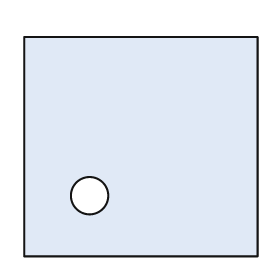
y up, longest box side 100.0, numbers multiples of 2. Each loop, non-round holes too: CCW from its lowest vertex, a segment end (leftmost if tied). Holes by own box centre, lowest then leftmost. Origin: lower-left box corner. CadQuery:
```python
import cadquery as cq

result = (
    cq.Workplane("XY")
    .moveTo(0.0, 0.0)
    .lineTo(100.0, 0.0)
    .lineTo(100.0, 94.0)
    .lineTo(0.0, 94.0)
    .close()
    .moveTo(28.0, 26.0)
    .circle(8.0)
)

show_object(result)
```